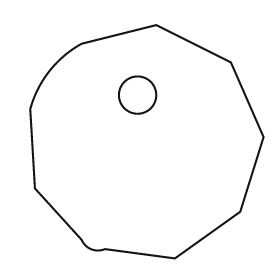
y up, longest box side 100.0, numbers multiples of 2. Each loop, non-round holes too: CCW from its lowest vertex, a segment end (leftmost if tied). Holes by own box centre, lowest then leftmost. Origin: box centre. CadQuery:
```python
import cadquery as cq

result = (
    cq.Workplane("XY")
    .moveTo(12.0, -50.0)
    .lineTo(40.0, -30.0)
    .lineTo(50.0, 2.0)
    .lineTo(36.0, 34.0)
    .lineTo(4.0, 50.0)
    .lineTo(-28.0, 42.0)
    .threePointArc((-42.0, 30.0), (-50.0, 14.0))
    .lineTo(-48.0, -20.0)
    .lineTo(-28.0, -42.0)
    .threePointArc((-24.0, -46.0), (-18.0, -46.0))
    .close()
    .moveTo(-4.0, 20.0)
    .circle(8.0)
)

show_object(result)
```